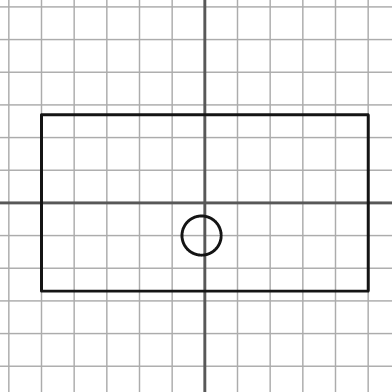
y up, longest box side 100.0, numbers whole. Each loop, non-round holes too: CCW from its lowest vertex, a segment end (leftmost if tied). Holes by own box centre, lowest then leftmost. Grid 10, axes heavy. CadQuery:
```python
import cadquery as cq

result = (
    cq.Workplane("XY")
    .moveTo(-50.0, -27.0)
    .lineTo(50.0, -27.0)
    .lineTo(50.0, 27.0)
    .lineTo(-50.0, 27.0)
    .close()
    .moveTo(-1.0, -10.0)
    .circle(6.0)
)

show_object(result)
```